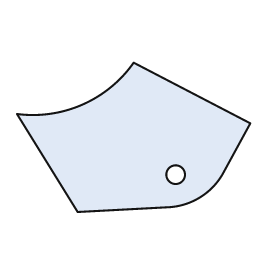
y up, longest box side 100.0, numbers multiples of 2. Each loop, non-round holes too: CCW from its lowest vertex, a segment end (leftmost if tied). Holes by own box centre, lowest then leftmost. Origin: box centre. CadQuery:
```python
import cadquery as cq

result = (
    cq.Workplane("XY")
    .moveTo(-24.0, -32.0)
    .lineTo(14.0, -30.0)
    .threePointArc((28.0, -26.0), (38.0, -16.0))
    .lineTo(50.0, 6.0)
    .lineTo(0.0, 32.0)
    .threePointArc((-22.0, 14.0), (-50.0, 10.0))
    .close()
    .moveTo(18.0, -16.0)
    .circle(4.0)
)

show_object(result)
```